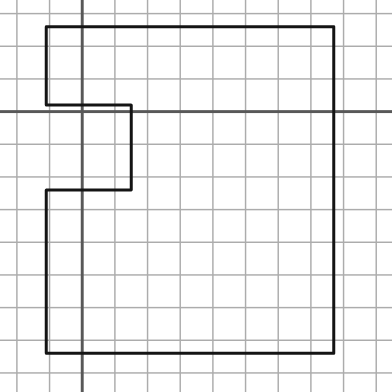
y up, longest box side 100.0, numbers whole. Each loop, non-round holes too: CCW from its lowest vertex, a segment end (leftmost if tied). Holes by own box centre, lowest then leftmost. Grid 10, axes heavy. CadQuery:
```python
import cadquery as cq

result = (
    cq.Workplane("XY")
    .moveTo(-11.0, -74.0)
    .lineTo(77.0, -74.0)
    .lineTo(77.0, 26.0)
    .lineTo(-11.0, 26.0)
    .lineTo(-11.0, 2.0)
    .lineTo(15.0, 2.0)
    .lineTo(15.0, -24.0)
    .lineTo(-11.0, -24.0)
    .close()
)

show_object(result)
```